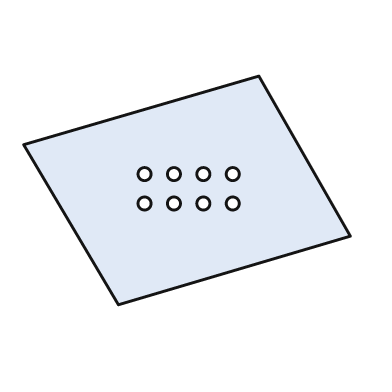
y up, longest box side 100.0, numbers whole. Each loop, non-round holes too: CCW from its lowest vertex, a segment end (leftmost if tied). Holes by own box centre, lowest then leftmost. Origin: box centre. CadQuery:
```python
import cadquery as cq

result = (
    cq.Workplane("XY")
    .moveTo(-21.0, -35.0)
    .lineTo(50.0, -14.0)
    .lineTo(22.0, 35.0)
    .lineTo(-50.0, 14.0)
    .close()
    .moveTo(-13.0, -4.0)
    .circle(2.0)
    .moveTo(-4.0, -4.0)
    .circle(2.0)
    .moveTo(5.0, -4.0)
    .circle(2.0)
    .moveTo(14.0, -4.0)
    .circle(2.0)
    .moveTo(-13.0, 5.0)
    .circle(2.0)
    .moveTo(-4.0, 5.0)
    .circle(2.0)
    .moveTo(5.0, 5.0)
    .circle(2.0)
    .moveTo(14.0, 5.0)
    .circle(2.0)
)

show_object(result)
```